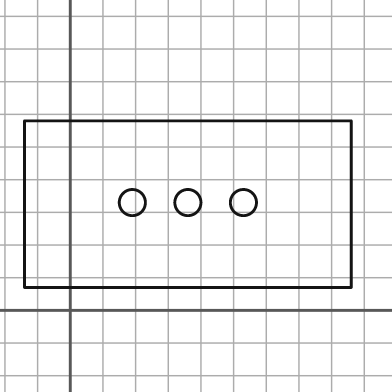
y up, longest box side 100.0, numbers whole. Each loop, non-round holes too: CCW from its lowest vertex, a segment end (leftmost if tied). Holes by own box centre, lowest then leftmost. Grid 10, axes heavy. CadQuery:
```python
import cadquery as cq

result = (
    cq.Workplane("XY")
    .moveTo(-14.0, 7.0)
    .lineTo(86.0, 7.0)
    .lineTo(86.0, 58.0)
    .lineTo(-14.0, 58.0)
    .close()
    .moveTo(19.0, 33.0)
    .circle(4.0)
    .moveTo(36.0, 33.0)
    .circle(4.0)
    .moveTo(53.0, 33.0)
    .circle(4.0)
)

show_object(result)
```